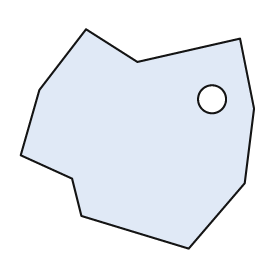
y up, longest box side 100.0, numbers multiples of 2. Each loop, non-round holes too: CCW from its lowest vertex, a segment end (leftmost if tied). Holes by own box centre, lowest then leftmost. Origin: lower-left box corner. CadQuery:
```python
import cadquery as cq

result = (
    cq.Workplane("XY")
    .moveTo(72.0, 0.0)
    .lineTo(96.0, 28.0)
    .lineTo(100.0, 60.0)
    .lineTo(94.0, 90.0)
    .lineTo(50.0, 80.0)
    .lineTo(28.0, 94.0)
    .lineTo(8.0, 68.0)
    .lineTo(0.0, 40.0)
    .lineTo(22.0, 30.0)
    .lineTo(26.0, 14.0)
    .close()
    .moveTo(82.0, 64.0)
    .circle(6.0)
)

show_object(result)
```